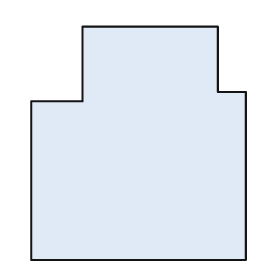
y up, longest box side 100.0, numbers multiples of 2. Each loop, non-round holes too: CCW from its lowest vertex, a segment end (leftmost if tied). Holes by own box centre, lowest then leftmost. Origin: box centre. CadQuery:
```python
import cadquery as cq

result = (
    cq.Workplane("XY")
    .moveTo(-46.0, -50.0)
    .lineTo(46.0, -50.0)
    .lineTo(46.0, 22.0)
    .lineTo(34.0, 22.0)
    .lineTo(34.0, 50.0)
    .lineTo(-24.0, 50.0)
    .lineTo(-24.0, 18.0)
    .lineTo(-46.0, 18.0)
    .close()
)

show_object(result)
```